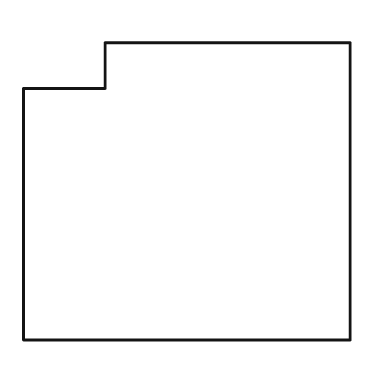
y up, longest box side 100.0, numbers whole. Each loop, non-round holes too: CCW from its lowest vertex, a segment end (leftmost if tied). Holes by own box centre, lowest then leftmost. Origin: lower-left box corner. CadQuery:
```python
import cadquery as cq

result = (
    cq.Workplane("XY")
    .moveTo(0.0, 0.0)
    .lineTo(100.0, 0.0)
    .lineTo(100.0, 91.0)
    .lineTo(25.0, 91.0)
    .lineTo(25.0, 77.0)
    .lineTo(0.0, 77.0)
    .close()
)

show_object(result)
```